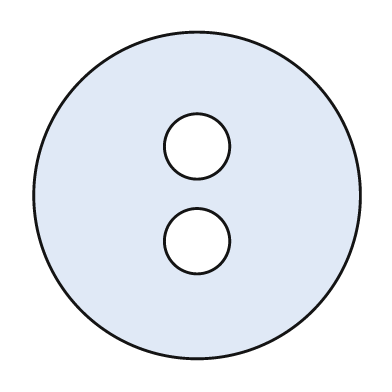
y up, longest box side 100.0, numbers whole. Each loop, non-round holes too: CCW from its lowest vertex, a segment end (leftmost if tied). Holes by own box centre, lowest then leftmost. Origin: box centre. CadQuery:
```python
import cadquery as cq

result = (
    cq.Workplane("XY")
    .moveTo(0.0, 0.0)
    .circle(50.0)
    .moveTo(0.0, -14.0)
    .circle(10.0)
    .moveTo(0.0, 15.0)
    .circle(10.0)
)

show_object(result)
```